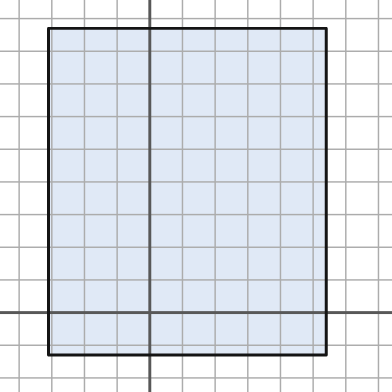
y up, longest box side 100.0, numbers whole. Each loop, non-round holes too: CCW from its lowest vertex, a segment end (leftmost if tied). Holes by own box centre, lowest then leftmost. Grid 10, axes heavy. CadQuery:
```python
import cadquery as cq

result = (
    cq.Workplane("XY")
    .moveTo(-31.0, -13.0)
    .lineTo(54.0, -13.0)
    .lineTo(54.0, 87.0)
    .lineTo(-31.0, 87.0)
    .close()
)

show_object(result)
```